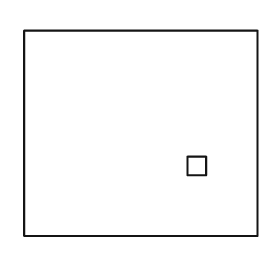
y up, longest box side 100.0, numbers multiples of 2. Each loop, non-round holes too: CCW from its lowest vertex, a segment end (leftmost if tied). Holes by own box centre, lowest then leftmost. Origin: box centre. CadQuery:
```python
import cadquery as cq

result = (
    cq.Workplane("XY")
    .moveTo(-50.0, -44.0)
    .lineTo(50.0, -44.0)
    .lineTo(50.0, 44.0)
    .lineTo(-50.0, 44.0)
    .close()
    .moveTo(20.0, -18.0)
    .lineTo(28.0, -18.0)
    .lineTo(28.0, -10.0)
    .lineTo(20.0, -10.0)
    .close()
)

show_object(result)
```